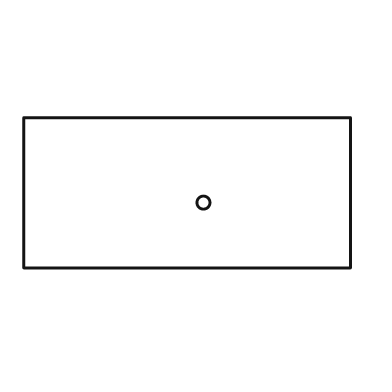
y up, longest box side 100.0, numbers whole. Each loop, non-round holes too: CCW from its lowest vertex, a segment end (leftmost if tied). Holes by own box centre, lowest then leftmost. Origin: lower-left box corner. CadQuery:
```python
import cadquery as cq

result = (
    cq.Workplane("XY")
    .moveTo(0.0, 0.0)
    .lineTo(100.0, 0.0)
    .lineTo(100.0, 46.0)
    .lineTo(0.0, 46.0)
    .close()
    .moveTo(55.0, 20.0)
    .circle(2.0)
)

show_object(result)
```